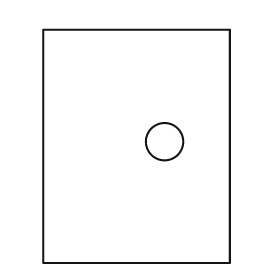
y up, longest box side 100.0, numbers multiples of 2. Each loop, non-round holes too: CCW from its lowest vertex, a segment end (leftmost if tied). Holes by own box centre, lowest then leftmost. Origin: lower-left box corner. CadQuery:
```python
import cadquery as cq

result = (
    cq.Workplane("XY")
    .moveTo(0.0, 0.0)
    .lineTo(80.0, 0.0)
    .lineTo(80.0, 100.0)
    .lineTo(0.0, 100.0)
    .close()
    .moveTo(52.0, 52.0)
    .circle(8.0)
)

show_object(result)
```